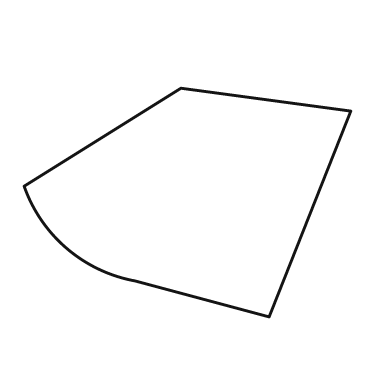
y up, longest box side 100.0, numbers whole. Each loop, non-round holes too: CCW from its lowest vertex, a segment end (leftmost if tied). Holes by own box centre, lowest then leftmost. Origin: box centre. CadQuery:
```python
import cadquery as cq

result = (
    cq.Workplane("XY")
    .moveTo(25.0, -35.0)
    .lineTo(50.0, 28.0)
    .lineTo(-2.0, 35.0)
    .lineTo(-50.0, 5.0)
    .threePointArc((-37.0, -14.0), (-16.0, -24.0))
    .close()
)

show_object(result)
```